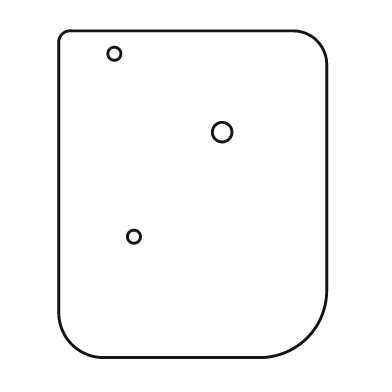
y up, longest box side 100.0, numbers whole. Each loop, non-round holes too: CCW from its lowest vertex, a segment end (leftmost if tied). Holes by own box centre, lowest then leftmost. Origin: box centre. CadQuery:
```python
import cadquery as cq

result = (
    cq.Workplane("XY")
    .moveTo(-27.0, -50.0)
    .lineTo(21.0, -50.0)
    .threePointArc((35.0, -44.0), (41.0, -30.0))
    .lineTo(41.0, 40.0)
    .threePointArc((38.0, 47.0), (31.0, 50.0))
    .lineTo(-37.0, 50.0)
    .threePointArc((-40.0, 49.0), (-41.0, 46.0))
    .lineTo(-41.0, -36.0)
    .threePointArc((-37.0, -46.0), (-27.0, -50.0))
    .close()
    .moveTo(-18.0, -13.0)
    .circle(2.0)
    .moveTo(9.0, 19.0)
    .circle(3.0)
    .moveTo(-24.0, 43.0)
    .circle(2.0)
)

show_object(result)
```